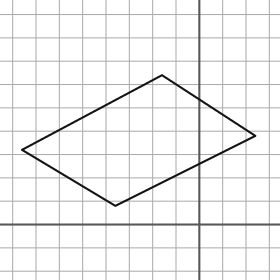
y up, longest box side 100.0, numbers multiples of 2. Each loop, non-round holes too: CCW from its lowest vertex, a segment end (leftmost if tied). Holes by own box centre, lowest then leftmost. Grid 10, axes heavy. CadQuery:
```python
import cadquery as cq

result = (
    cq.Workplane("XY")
    .moveTo(-36.0, 8.0)
    .lineTo(24.0, 38.0)
    .lineTo(-16.0, 64.0)
    .lineTo(-76.0, 32.0)
    .close()
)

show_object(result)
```